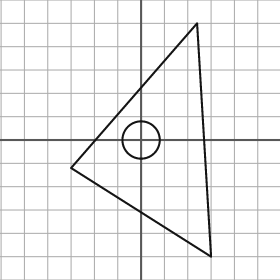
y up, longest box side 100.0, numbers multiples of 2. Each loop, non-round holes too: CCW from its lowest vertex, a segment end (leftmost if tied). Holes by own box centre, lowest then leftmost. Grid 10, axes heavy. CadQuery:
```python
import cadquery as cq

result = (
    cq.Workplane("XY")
    .moveTo(30.0, -50.0)
    .lineTo(24.0, 50.0)
    .lineTo(-30.0, -12.0)
    .close()
    .moveTo(0.0, 0.0)
    .circle(8.0)
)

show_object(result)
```